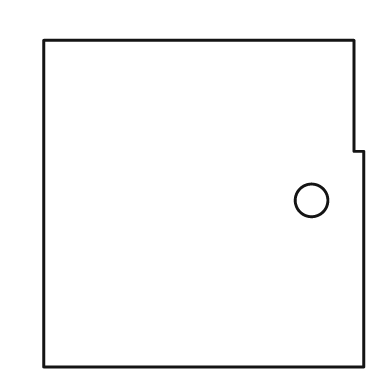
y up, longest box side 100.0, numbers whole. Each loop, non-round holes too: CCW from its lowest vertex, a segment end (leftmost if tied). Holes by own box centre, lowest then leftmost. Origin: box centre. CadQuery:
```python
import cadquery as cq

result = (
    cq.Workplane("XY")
    .moveTo(-49.0, -50.0)
    .lineTo(49.0, -50.0)
    .lineTo(49.0, 16.0)
    .lineTo(46.0, 16.0)
    .lineTo(46.0, 50.0)
    .lineTo(-49.0, 50.0)
    .close()
    .moveTo(33.0, 1.0)
    .circle(5.0)
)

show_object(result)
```